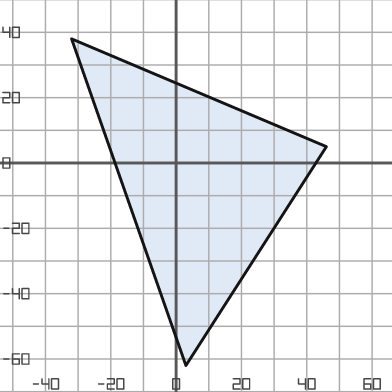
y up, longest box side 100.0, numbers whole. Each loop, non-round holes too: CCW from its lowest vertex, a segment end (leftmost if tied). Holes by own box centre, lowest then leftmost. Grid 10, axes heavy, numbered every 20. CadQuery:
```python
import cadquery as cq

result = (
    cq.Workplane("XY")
    .moveTo(3.0, -62.0)
    .lineTo(46.0, 5.0)
    .lineTo(-32.0, 38.0)
    .close()
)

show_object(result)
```